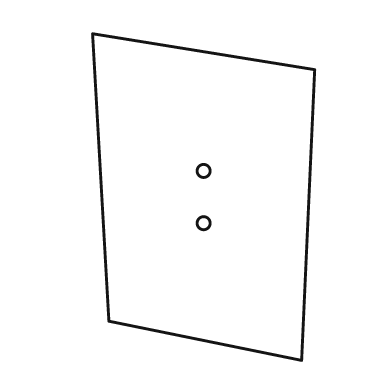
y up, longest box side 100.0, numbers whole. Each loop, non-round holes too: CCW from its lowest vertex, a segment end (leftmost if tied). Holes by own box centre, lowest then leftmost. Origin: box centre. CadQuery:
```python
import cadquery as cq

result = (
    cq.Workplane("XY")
    .moveTo(30.0, -50.0)
    .lineTo(34.0, 39.0)
    .lineTo(-34.0, 50.0)
    .lineTo(-29.0, -38.0)
    .close()
    .moveTo(0.0, -8.0)
    .circle(2.0)
    .moveTo(0.0, 8.0)
    .circle(2.0)
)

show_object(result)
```